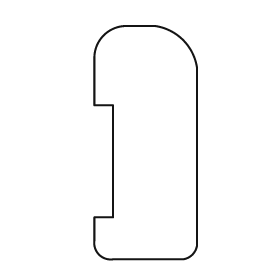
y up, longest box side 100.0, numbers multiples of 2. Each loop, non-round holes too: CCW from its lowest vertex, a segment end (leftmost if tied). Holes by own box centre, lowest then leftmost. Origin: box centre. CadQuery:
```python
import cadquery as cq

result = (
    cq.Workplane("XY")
    .moveTo(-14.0, -50.0)
    .lineTo(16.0, -50.0)
    .threePointArc((20.0, -48.0), (22.0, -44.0))
    .lineTo(22.0, 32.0)
    .threePointArc((16.0, 44.0), (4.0, 50.0))
    .lineTo(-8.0, 50.0)
    .threePointArc((-18.0, 46.0), (-22.0, 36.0))
    .lineTo(-22.0, 16.0)
    .lineTo(-14.0, 16.0)
    .lineTo(-14.0, -32.0)
    .lineTo(-22.0, -32.0)
    .lineTo(-22.0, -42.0)
    .threePointArc((-20.0, -48.0), (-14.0, -50.0))
    .close()
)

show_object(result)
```